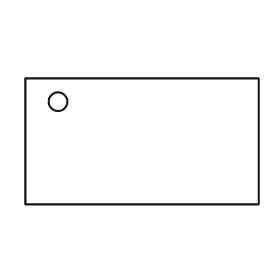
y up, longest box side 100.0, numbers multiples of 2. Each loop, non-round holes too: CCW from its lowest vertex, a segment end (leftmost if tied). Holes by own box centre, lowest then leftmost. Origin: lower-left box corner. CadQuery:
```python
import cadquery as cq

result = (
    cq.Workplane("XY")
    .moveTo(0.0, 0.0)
    .lineTo(100.0, 0.0)
    .lineTo(100.0, 54.0)
    .lineTo(0.0, 54.0)
    .close()
    .moveTo(14.0, 44.0)
    .circle(4.0)
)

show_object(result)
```